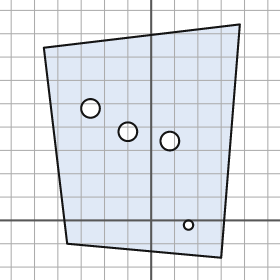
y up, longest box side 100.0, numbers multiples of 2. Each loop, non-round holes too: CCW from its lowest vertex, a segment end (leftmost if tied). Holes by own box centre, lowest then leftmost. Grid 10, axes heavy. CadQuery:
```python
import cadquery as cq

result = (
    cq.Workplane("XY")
    .moveTo(30.0, -16.0)
    .lineTo(38.0, 84.0)
    .lineTo(-46.0, 74.0)
    .lineTo(-36.0, -10.0)
    .close()
    .moveTo(16.0, -2.0)
    .circle(2.0)
    .moveTo(8.0, 34.0)
    .circle(4.0)
    .moveTo(-10.0, 38.0)
    .circle(4.0)
    .moveTo(-26.0, 48.0)
    .circle(4.0)
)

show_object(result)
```